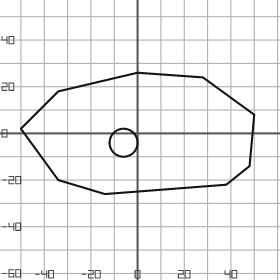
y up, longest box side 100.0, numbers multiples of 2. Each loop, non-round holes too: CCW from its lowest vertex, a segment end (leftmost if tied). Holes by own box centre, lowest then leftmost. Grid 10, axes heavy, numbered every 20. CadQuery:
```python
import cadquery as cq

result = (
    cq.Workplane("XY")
    .moveTo(-14.0, -26.0)
    .lineTo(38.0, -22.0)
    .lineTo(48.0, -14.0)
    .lineTo(50.0, 8.0)
    .lineTo(28.0, 24.0)
    .lineTo(0.0, 26.0)
    .lineTo(-34.0, 18.0)
    .lineTo(-50.0, 2.0)
    .lineTo(-34.0, -20.0)
    .close()
    .moveTo(-6.0, -4.0)
    .circle(6.0)
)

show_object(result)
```